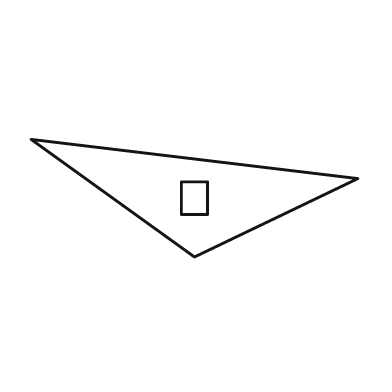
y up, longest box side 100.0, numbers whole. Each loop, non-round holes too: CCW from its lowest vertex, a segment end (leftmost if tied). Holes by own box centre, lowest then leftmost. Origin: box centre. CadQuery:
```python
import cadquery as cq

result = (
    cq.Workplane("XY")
    .moveTo(0.0, -18.0)
    .lineTo(50.0, 6.0)
    .lineTo(-50.0, 18.0)
    .close()
    .moveTo(-4.0, -5.0)
    .lineTo(4.0, -5.0)
    .lineTo(4.0, 5.0)
    .lineTo(-4.0, 5.0)
    .close()
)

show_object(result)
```